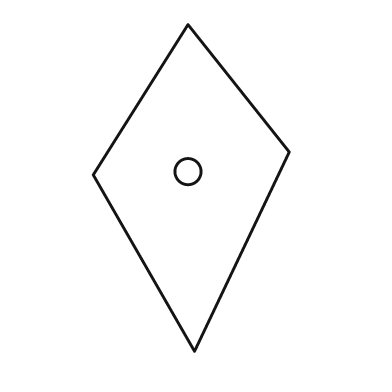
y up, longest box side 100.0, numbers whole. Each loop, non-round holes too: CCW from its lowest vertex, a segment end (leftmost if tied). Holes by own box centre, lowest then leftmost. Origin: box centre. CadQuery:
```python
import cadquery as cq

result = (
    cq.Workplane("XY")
    .moveTo(1.0, -50.0)
    .lineTo(30.0, 11.0)
    .lineTo(-1.0, 50.0)
    .lineTo(-30.0, 4.0)
    .close()
    .moveTo(-1.0, 5.0)
    .circle(4.0)
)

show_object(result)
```